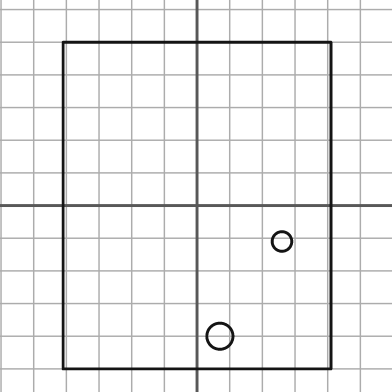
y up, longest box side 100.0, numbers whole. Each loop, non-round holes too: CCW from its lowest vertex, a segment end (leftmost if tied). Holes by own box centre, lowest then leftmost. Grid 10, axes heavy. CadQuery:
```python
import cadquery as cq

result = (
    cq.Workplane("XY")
    .moveTo(-41.0, -50.0)
    .lineTo(41.0, -50.0)
    .lineTo(41.0, 50.0)
    .lineTo(-41.0, 50.0)
    .close()
    .moveTo(7.0, -40.0)
    .circle(4.0)
    .moveTo(26.0, -11.0)
    .circle(3.0)
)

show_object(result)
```